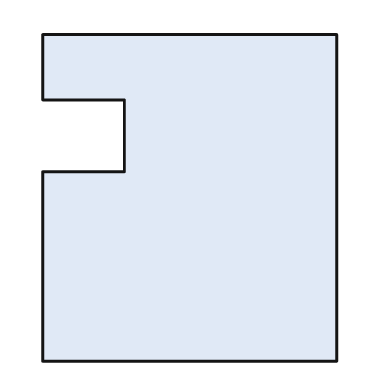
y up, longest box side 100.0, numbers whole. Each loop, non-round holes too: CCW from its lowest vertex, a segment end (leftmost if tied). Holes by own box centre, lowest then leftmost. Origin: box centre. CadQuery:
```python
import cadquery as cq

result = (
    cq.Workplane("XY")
    .moveTo(-45.0, -50.0)
    .lineTo(45.0, -50.0)
    .lineTo(45.0, 50.0)
    .lineTo(-45.0, 50.0)
    .lineTo(-45.0, 30.0)
    .lineTo(-20.0, 30.0)
    .lineTo(-20.0, 8.0)
    .lineTo(-45.0, 8.0)
    .close()
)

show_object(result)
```